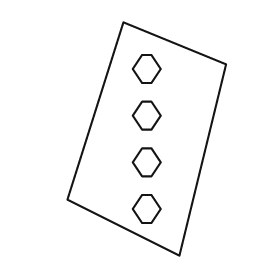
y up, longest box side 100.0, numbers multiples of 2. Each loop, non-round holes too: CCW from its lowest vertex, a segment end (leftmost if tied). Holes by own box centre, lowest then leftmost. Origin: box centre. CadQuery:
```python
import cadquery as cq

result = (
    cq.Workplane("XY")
    .moveTo(14.0, -50.0)
    .lineTo(34.0, 32.0)
    .lineTo(-10.0, 50.0)
    .lineTo(-34.0, -26.0)
    .close()
    .moveTo(-2.0, -36.0)
    .lineTo(2.0, -36.0)
    .lineTo(6.0, -30.0)
    .lineTo(2.0, -24.0)
    .lineTo(-2.0, -24.0)
    .lineTo(-6.0, -30.0)
    .close()
    .moveTo(-2.0, -16.0)
    .lineTo(2.0, -16.0)
    .lineTo(6.0, -10.0)
    .lineTo(2.0, -4.0)
    .lineTo(-2.0, -4.0)
    .lineTo(-6.0, -10.0)
    .close()
    .moveTo(-2.0, 4.0)
    .lineTo(2.0, 4.0)
    .lineTo(6.0, 10.0)
    .lineTo(2.0, 16.0)
    .lineTo(-2.0, 16.0)
    .lineTo(-6.0, 10.0)
    .close()
    .moveTo(-2.0, 24.0)
    .lineTo(2.0, 24.0)
    .lineTo(6.0, 30.0)
    .lineTo(2.0, 36.0)
    .lineTo(-2.0, 36.0)
    .lineTo(-6.0, 30.0)
    .close()
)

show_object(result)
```